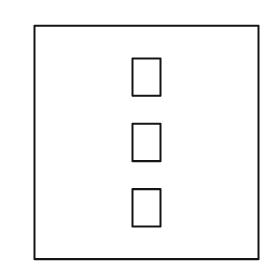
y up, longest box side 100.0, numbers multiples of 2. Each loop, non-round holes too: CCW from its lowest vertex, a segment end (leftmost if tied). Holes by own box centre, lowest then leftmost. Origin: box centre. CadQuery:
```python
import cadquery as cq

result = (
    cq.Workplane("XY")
    .moveTo(-48.0, -50.0)
    .lineTo(48.0, -50.0)
    .lineTo(48.0, 50.0)
    .lineTo(-48.0, 50.0)
    .close()
    .moveTo(-6.0, -36.0)
    .lineTo(6.0, -36.0)
    .lineTo(6.0, -20.0)
    .lineTo(-6.0, -20.0)
    .close()
    .moveTo(-6.0, -8.0)
    .lineTo(6.0, -8.0)
    .lineTo(6.0, 8.0)
    .lineTo(-6.0, 8.0)
    .close()
    .moveTo(-6.0, 20.0)
    .lineTo(6.0, 20.0)
    .lineTo(6.0, 36.0)
    .lineTo(-6.0, 36.0)
    .close()
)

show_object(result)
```